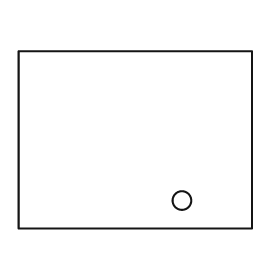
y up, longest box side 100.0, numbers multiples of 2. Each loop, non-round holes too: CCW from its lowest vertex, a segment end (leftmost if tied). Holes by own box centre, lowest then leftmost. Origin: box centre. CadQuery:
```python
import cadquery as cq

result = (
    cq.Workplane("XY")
    .moveTo(-50.0, -38.0)
    .lineTo(50.0, -38.0)
    .lineTo(50.0, 38.0)
    .lineTo(-50.0, 38.0)
    .close()
    .moveTo(20.0, -26.0)
    .circle(4.0)
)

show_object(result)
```